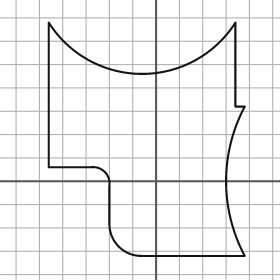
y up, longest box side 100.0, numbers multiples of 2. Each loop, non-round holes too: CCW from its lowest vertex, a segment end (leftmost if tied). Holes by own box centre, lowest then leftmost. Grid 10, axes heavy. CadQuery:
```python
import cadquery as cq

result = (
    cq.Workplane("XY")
    .moveTo(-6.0, -32.0)
    .lineTo(38.0, -32.0)
    .threePointArc((30.0, 0.0), (38.0, 32.0))
    .lineTo(34.0, 32.0)
    .lineTo(34.0, 68.0)
    .threePointArc((-6.0, 46.0), (-46.0, 68.0))
    .lineTo(-46.0, 6.0)
    .lineTo(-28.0, 6.0)
    .threePointArc((-22.0, 4.0), (-20.0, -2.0))
    .lineTo(-20.0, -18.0)
    .threePointArc((-16.0, -28.0), (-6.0, -32.0))
    .close()
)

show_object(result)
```